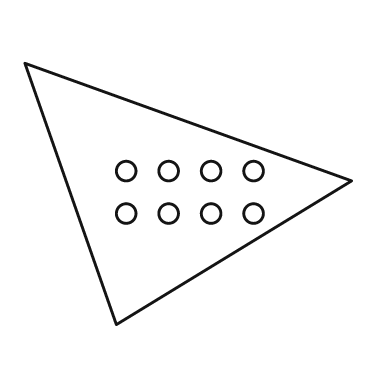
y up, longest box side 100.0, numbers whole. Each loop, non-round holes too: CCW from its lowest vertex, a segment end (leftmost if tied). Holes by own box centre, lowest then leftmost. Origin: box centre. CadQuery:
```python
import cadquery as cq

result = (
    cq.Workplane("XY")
    .moveTo(-22.0, -40.0)
    .lineTo(50.0, 4.0)
    .lineTo(-50.0, 40.0)
    .close()
    .moveTo(-19.0, -6.0)
    .circle(3.0)
    .moveTo(-6.0, -6.0)
    .circle(3.0)
    .moveTo(7.0, -6.0)
    .circle(3.0)
    .moveTo(20.0, -6.0)
    .circle(3.0)
    .moveTo(-19.0, 7.0)
    .circle(3.0)
    .moveTo(-6.0, 7.0)
    .circle(3.0)
    .moveTo(7.0, 7.0)
    .circle(3.0)
    .moveTo(20.0, 7.0)
    .circle(3.0)
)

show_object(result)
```